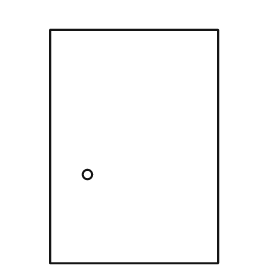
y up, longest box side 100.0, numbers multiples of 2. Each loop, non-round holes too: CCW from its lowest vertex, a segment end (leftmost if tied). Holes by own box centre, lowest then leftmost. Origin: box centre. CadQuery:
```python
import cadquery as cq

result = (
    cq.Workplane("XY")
    .moveTo(-36.0, -50.0)
    .lineTo(36.0, -50.0)
    .lineTo(36.0, 50.0)
    .lineTo(-36.0, 50.0)
    .close()
    .moveTo(-20.0, -12.0)
    .circle(2.0)
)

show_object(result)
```